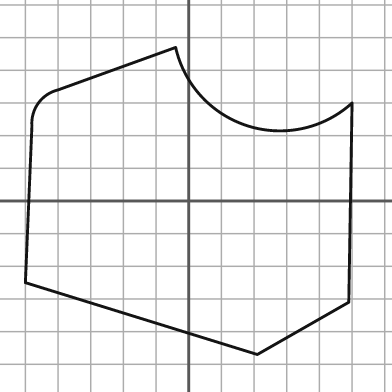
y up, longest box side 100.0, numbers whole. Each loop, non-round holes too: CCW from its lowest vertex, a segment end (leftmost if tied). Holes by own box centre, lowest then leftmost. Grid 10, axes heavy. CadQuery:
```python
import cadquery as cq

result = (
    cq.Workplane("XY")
    .moveTo(21.0, -47.0)
    .lineTo(49.0, -31.0)
    .lineTo(50.0, 30.0)
    .threePointArc((18.0, 23.0), (-4.0, 47.0))
    .lineTo(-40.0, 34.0)
    .threePointArc((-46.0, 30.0), (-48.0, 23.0))
    .lineTo(-50.0, -25.0)
    .close()
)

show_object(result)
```